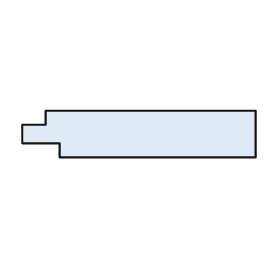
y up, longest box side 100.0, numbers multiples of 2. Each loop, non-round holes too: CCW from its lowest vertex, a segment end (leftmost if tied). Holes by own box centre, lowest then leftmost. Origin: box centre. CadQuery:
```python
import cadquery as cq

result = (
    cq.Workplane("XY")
    .moveTo(-34.0, -10.0)
    .lineTo(50.0, -10.0)
    .lineTo(50.0, 10.0)
    .lineTo(-40.0, 10.0)
    .lineTo(-40.0, 4.0)
    .lineTo(-50.0, 4.0)
    .lineTo(-50.0, -4.0)
    .lineTo(-34.0, -4.0)
    .close()
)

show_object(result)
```